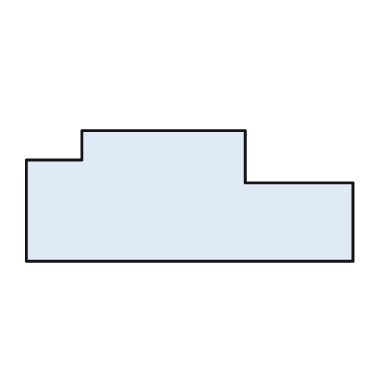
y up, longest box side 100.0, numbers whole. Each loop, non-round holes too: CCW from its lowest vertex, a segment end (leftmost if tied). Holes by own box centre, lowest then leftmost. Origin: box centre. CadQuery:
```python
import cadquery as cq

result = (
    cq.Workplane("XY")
    .moveTo(-50.0, -20.0)
    .lineTo(50.0, -20.0)
    .lineTo(50.0, 4.0)
    .lineTo(17.0, 4.0)
    .lineTo(17.0, 20.0)
    .lineTo(-33.0, 20.0)
    .lineTo(-33.0, 11.0)
    .lineTo(-50.0, 11.0)
    .close()
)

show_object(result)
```